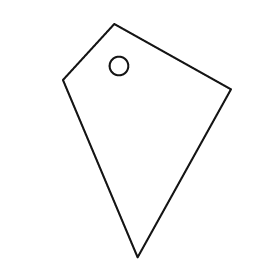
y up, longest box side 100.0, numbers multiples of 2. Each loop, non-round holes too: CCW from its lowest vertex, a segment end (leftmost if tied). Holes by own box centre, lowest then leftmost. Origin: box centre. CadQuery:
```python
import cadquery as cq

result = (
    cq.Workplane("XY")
    .moveTo(-4.0, -50.0)
    .lineTo(36.0, 22.0)
    .lineTo(-14.0, 50.0)
    .lineTo(-36.0, 26.0)
    .close()
    .moveTo(-12.0, 32.0)
    .circle(4.0)
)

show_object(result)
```